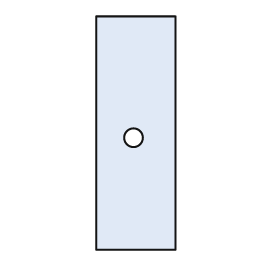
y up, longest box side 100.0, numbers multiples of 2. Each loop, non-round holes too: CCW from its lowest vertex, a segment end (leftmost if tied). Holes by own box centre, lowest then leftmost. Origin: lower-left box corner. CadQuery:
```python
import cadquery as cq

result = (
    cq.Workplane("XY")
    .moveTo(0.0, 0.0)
    .lineTo(34.0, 0.0)
    .lineTo(34.0, 100.0)
    .lineTo(0.0, 100.0)
    .close()
    .moveTo(16.0, 48.0)
    .circle(4.0)
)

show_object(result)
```